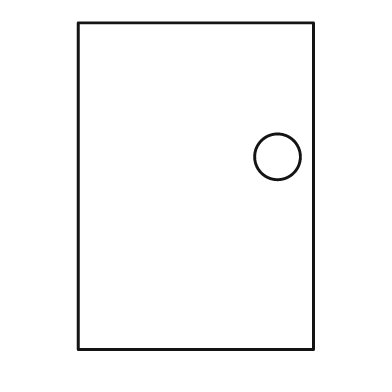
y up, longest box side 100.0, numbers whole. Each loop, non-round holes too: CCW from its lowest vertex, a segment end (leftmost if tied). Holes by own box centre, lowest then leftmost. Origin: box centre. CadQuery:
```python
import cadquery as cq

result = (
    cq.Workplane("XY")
    .moveTo(-36.0, -50.0)
    .lineTo(36.0, -50.0)
    .lineTo(36.0, 50.0)
    .lineTo(-36.0, 50.0)
    .close()
    .moveTo(25.0, 9.0)
    .circle(7.0)
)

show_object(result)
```